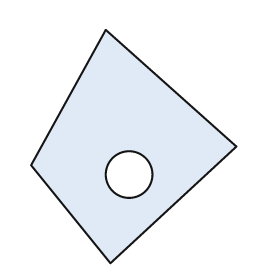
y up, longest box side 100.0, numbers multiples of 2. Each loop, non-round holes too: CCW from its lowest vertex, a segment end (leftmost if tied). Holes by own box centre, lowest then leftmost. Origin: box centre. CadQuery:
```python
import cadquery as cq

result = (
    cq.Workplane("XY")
    .moveTo(-10.0, -50.0)
    .lineTo(44.0, 0.0)
    .lineTo(-12.0, 50.0)
    .lineTo(-44.0, -8.0)
    .close()
    .moveTo(-2.0, -12.0)
    .circle(10.0)
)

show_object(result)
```